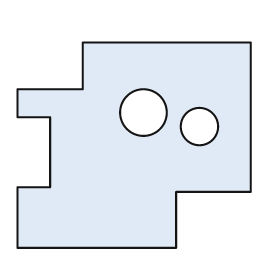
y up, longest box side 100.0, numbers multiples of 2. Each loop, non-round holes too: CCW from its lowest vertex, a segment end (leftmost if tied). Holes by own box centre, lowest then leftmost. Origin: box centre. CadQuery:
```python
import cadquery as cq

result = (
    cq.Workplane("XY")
    .moveTo(-50.0, -44.0)
    .lineTo(18.0, -44.0)
    .lineTo(18.0, -20.0)
    .lineTo(50.0, -20.0)
    .lineTo(50.0, 44.0)
    .lineTo(-22.0, 44.0)
    .lineTo(-22.0, 24.0)
    .lineTo(-50.0, 24.0)
    .lineTo(-50.0, 12.0)
    .lineTo(-36.0, 12.0)
    .lineTo(-36.0, -18.0)
    .lineTo(-50.0, -18.0)
    .close()
    .moveTo(28.0, 8.0)
    .circle(8.0)
    .moveTo(4.0, 14.0)
    .circle(10.0)
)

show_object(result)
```